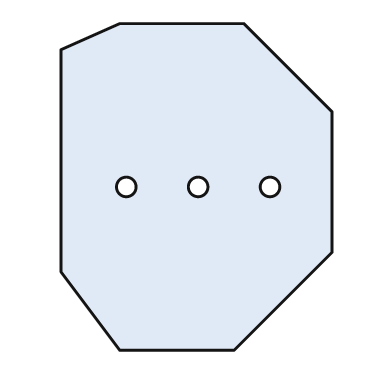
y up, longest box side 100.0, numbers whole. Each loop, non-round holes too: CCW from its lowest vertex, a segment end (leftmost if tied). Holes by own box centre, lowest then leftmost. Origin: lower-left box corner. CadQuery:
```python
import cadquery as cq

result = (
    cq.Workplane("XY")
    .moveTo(18.0, 0.0)
    .lineTo(53.0, 0.0)
    .lineTo(83.0, 30.0)
    .lineTo(83.0, 73.0)
    .lineTo(56.0, 100.0)
    .lineTo(18.0, 100.0)
    .lineTo(0.0, 92.0)
    .lineTo(0.0, 24.0)
    .close()
    .moveTo(20.0, 50.0)
    .circle(3.0)
    .moveTo(42.0, 50.0)
    .circle(3.0)
    .moveTo(64.0, 50.0)
    .circle(3.0)
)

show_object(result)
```